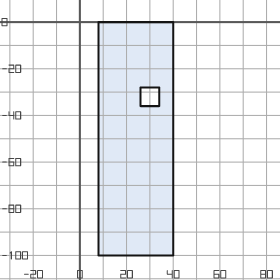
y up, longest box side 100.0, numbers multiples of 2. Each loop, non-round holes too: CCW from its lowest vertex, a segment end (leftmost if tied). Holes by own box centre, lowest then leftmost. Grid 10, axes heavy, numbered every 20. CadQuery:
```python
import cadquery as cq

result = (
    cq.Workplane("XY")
    .moveTo(8.0, -100.0)
    .lineTo(40.0, -100.0)
    .lineTo(40.0, 0.0)
    .lineTo(8.0, 0.0)
    .close()
    .moveTo(26.0, -36.0)
    .lineTo(34.0, -36.0)
    .lineTo(34.0, -28.0)
    .lineTo(26.0, -28.0)
    .close()
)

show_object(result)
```